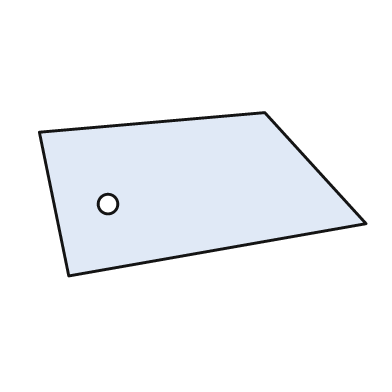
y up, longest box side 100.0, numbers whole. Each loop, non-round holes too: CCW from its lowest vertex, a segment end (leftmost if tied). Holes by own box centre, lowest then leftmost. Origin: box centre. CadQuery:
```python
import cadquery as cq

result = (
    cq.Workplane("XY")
    .moveTo(-41.0, -25.0)
    .lineTo(50.0, -9.0)
    .lineTo(19.0, 25.0)
    .lineTo(-50.0, 19.0)
    .close()
    .moveTo(-29.0, -3.0)
    .circle(3.0)
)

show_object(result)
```